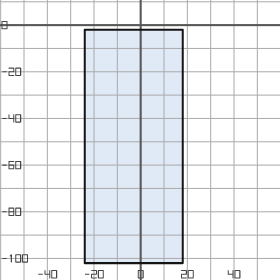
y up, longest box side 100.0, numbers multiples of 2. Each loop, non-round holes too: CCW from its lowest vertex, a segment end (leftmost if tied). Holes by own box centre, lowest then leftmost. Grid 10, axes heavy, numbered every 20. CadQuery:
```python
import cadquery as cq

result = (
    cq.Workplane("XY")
    .moveTo(-24.0, -102.0)
    .lineTo(18.0, -102.0)
    .lineTo(18.0, -2.0)
    .lineTo(-24.0, -2.0)
    .close()
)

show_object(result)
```